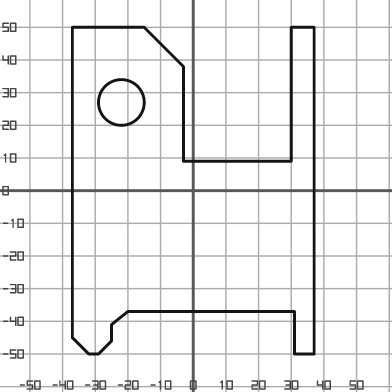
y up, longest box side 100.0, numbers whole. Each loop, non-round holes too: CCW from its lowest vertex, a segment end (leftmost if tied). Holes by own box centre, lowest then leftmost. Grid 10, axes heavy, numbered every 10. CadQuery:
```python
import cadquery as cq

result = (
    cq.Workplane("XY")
    .moveTo(-32.0, -50.0)
    .lineTo(-29.0, -50.0)
    .lineTo(-25.0, -46.0)
    .lineTo(-25.0, -41.0)
    .lineTo(-20.0, -37.0)
    .lineTo(31.0, -37.0)
    .lineTo(31.0, -50.0)
    .lineTo(37.0, -50.0)
    .lineTo(37.0, 50.0)
    .lineTo(30.0, 50.0)
    .lineTo(30.0, 9.0)
    .lineTo(-3.0, 9.0)
    .lineTo(-3.0, 38.0)
    .lineTo(-15.0, 50.0)
    .lineTo(-37.0, 50.0)
    .lineTo(-37.0, -45.0)
    .close()
    .moveTo(-22.0, 27.0)
    .circle(7.0)
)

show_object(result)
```